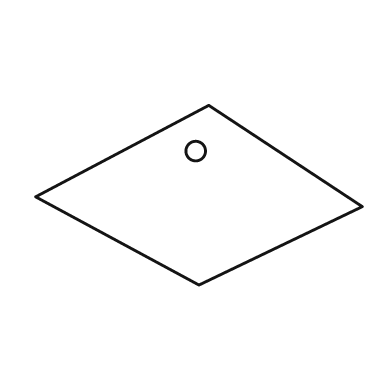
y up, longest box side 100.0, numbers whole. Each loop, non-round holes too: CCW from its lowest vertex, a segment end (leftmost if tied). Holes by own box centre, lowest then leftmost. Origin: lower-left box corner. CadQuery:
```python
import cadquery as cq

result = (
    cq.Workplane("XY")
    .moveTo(50.0, 0.0)
    .lineTo(100.0, 24.0)
    .lineTo(53.0, 55.0)
    .lineTo(0.0, 27.0)
    .close()
    .moveTo(49.0, 41.0)
    .circle(3.0)
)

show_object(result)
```